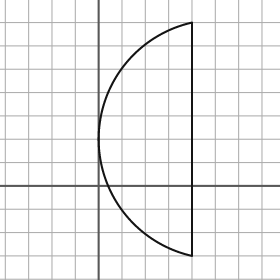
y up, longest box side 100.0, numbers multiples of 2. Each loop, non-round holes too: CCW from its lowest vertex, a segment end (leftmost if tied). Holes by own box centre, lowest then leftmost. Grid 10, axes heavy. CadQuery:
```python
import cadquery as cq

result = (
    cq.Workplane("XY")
    .moveTo(40.0, -30.0)
    .lineTo(40.0, 70.0)
    .threePointArc((0.0, 20.0), (40.0, -30.0))
    .close()
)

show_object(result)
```